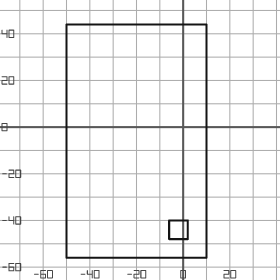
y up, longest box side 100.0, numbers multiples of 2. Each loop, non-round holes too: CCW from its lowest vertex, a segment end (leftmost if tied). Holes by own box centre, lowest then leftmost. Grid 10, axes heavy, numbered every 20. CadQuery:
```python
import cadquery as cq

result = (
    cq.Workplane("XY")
    .moveTo(-50.0, -56.0)
    .lineTo(10.0, -56.0)
    .lineTo(10.0, 44.0)
    .lineTo(-50.0, 44.0)
    .close()
    .moveTo(-6.0, -48.0)
    .lineTo(2.0, -48.0)
    .lineTo(2.0, -40.0)
    .lineTo(-6.0, -40.0)
    .close()
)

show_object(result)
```